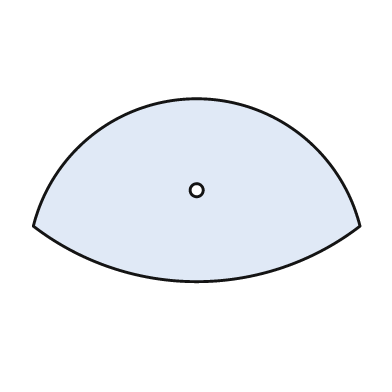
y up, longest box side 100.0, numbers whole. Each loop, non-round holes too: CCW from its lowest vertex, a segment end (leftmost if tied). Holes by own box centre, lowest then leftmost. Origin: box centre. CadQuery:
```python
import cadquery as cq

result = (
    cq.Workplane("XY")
    .moveTo(-50.0, -11.0)
    .threePointArc((0.0, -28.0), (50.0, -11.0))
    .threePointArc((0.0, 28.0), (-50.0, -11.0))
    .close()
    .moveTo(0.0, 0.0)
    .circle(2.0)
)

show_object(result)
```